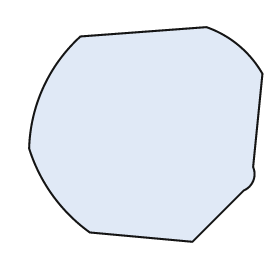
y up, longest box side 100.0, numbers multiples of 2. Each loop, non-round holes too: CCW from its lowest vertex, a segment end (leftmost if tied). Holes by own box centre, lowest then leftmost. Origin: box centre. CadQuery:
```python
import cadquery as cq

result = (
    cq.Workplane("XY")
    .moveTo(20.0, -46.0)
    .lineTo(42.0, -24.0)
    .threePointArc((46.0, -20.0), (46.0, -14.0))
    .lineTo(50.0, 26.0)
    .threePointArc((40.0, 38.0), (26.0, 46.0))
    .lineTo(-28.0, 42.0)
    .threePointArc((-44.0, 20.0), (-50.0, -6.0))
    .threePointArc((-40.0, -26.0), (-24.0, -42.0))
    .close()
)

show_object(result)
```